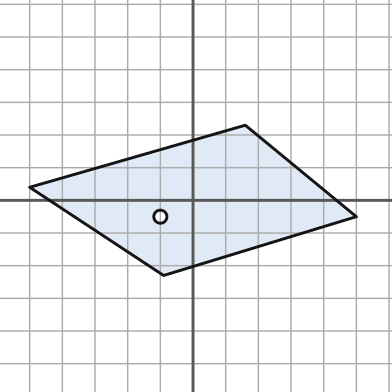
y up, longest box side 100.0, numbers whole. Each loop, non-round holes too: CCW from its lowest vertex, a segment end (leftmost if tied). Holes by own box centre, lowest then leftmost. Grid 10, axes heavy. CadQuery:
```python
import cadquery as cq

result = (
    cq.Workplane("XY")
    .moveTo(-9.0, -23.0)
    .lineTo(50.0, -5.0)
    .lineTo(16.0, 23.0)
    .lineTo(-50.0, 4.0)
    .close()
    .moveTo(-10.0, -5.0)
    .circle(2.0)
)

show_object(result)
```